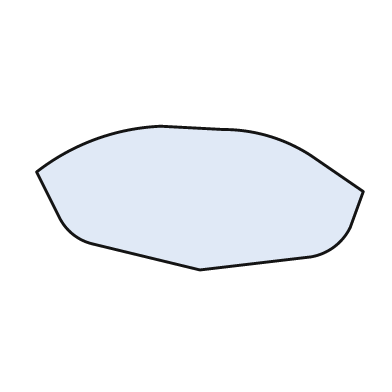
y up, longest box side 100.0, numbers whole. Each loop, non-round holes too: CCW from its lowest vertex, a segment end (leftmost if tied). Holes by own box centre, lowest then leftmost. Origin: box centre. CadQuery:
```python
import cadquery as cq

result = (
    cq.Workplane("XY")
    .moveTo(0.0, -22.0)
    .lineTo(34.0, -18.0)
    .threePointArc((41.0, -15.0), (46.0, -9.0))
    .lineTo(50.0, 2.0)
    .lineTo(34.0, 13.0)
    .threePointArc((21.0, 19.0), (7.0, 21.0))
    .lineTo(-12.0, 22.0)
    .threePointArc((-32.0, 18.0), (-50.0, 8.0))
    .lineTo(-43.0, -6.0)
    .threePointArc((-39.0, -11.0), (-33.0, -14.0))
    .close()
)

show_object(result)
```